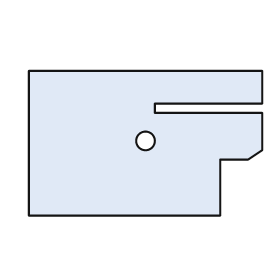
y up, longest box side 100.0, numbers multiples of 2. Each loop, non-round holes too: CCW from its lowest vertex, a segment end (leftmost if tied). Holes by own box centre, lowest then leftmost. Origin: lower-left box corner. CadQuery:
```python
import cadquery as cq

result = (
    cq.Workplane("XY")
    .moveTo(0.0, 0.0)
    .lineTo(82.0, 0.0)
    .lineTo(82.0, 24.0)
    .lineTo(94.0, 24.0)
    .lineTo(100.0, 28.0)
    .lineTo(100.0, 44.0)
    .lineTo(54.0, 44.0)
    .lineTo(54.0, 48.0)
    .lineTo(100.0, 48.0)
    .lineTo(100.0, 62.0)
    .lineTo(0.0, 62.0)
    .close()
    .moveTo(50.0, 32.0)
    .circle(4.0)
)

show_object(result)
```